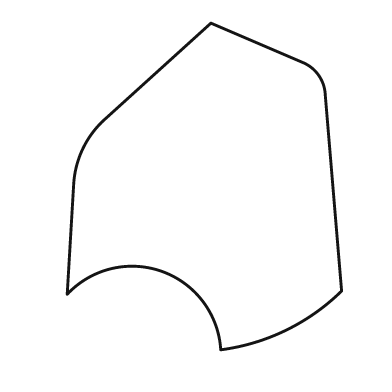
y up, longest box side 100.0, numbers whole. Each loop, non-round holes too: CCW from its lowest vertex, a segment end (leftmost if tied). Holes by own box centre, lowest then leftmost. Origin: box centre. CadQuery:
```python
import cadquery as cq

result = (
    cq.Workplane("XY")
    .moveTo(5.0, -50.0)
    .threePointArc((25.0, -44.0), (42.0, -32.0))
    .lineTo(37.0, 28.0)
    .threePointArc((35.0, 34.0), (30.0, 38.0))
    .lineTo(2.0, 50.0)
    .lineTo(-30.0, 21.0)
    .threePointArc((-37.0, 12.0), (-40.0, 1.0))
    .lineTo(-42.0, -33.0)
    .threePointArc((-13.0, -26.0), (5.0, -50.0))
    .close()
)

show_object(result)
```